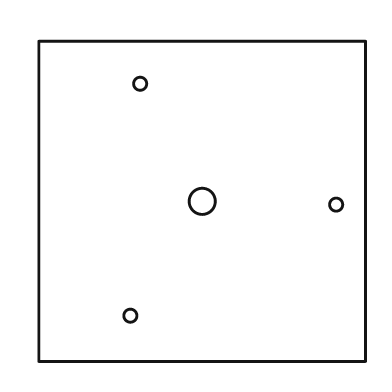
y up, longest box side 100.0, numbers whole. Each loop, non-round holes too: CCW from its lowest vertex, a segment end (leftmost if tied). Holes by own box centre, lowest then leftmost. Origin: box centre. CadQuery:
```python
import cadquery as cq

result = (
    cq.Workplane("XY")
    .moveTo(-50.0, -49.0)
    .lineTo(50.0, -49.0)
    .lineTo(50.0, 49.0)
    .lineTo(-50.0, 49.0)
    .close()
    .moveTo(-22.0, -35.0)
    .circle(2.0)
    .moveTo(41.0, -1.0)
    .circle(2.0)
    .moveTo(0.0, 0.0)
    .circle(4.0)
    .moveTo(-19.0, 36.0)
    .circle(2.0)
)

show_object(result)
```